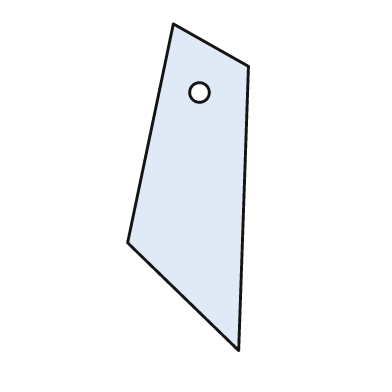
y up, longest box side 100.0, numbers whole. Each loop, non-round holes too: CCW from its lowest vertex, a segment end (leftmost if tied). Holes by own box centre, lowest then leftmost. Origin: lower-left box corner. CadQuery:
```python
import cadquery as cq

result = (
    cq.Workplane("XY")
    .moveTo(34.0, 0.0)
    .lineTo(37.0, 87.0)
    .lineTo(14.0, 100.0)
    .lineTo(0.0, 33.0)
    .close()
    .moveTo(22.0, 79.0)
    .circle(3.0)
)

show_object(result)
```